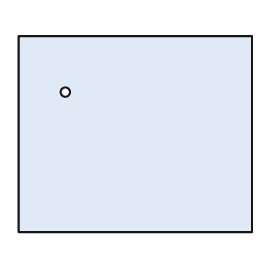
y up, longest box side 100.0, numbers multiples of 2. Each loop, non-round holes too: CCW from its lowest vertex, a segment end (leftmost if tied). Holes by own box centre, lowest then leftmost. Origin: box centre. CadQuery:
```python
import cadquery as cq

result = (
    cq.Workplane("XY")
    .moveTo(-50.0, -42.0)
    .lineTo(50.0, -42.0)
    .lineTo(50.0, 42.0)
    .lineTo(-50.0, 42.0)
    .close()
    .moveTo(-30.0, 18.0)
    .circle(2.0)
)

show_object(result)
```